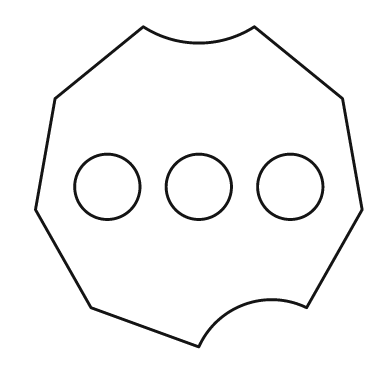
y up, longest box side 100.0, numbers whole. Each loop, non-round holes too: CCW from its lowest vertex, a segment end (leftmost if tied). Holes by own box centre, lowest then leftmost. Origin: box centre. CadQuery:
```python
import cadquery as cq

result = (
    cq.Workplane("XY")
    .moveTo(0.0, -49.0)
    .threePointArc((14.0, -36.0), (33.0, -37.0))
    .lineTo(50.0, -7.0)
    .lineTo(44.0, 27.0)
    .lineTo(17.0, 49.0)
    .threePointArc((0.0, 44.0), (-17.0, 49.0))
    .lineTo(-44.0, 27.0)
    .lineTo(-50.0, -7.0)
    .lineTo(-33.0, -37.0)
    .close()
    .moveTo(-28.0, 0.0)
    .circle(10.0)
    .moveTo(0.0, 0.0)
    .circle(10.0)
    .moveTo(28.0, 0.0)
    .circle(10.0)
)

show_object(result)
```